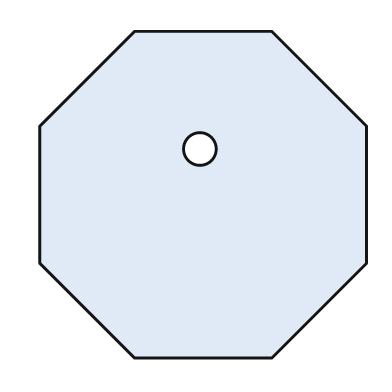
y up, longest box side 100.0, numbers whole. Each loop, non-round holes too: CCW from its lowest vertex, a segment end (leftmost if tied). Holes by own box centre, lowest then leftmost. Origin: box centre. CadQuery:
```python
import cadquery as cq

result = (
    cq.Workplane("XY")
    .moveTo(-21.0, -50.0)
    .lineTo(21.0, -50.0)
    .lineTo(50.0, -21.0)
    .lineTo(50.0, 21.0)
    .lineTo(21.0, 50.0)
    .lineTo(-21.0, 50.0)
    .lineTo(-50.0, 21.0)
    .lineTo(-50.0, -21.0)
    .close()
    .moveTo(-1.0, 14.0)
    .circle(5.0)
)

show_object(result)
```